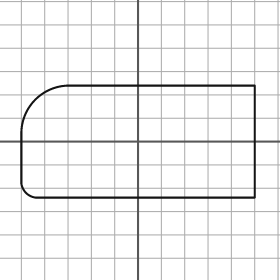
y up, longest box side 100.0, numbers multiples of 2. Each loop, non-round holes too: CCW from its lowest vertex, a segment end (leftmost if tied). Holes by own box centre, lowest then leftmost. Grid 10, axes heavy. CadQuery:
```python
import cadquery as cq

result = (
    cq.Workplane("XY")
    .moveTo(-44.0, -24.0)
    .lineTo(50.0, -24.0)
    .lineTo(50.0, 24.0)
    .lineTo(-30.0, 24.0)
    .threePointArc((-44.0, 18.0), (-50.0, 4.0))
    .lineTo(-50.0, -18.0)
    .threePointArc((-48.0, -22.0), (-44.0, -24.0))
    .close()
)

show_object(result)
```